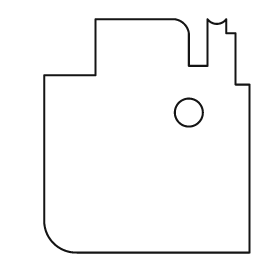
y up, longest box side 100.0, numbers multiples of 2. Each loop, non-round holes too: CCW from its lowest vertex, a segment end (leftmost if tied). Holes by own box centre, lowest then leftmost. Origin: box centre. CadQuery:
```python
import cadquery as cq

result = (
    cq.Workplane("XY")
    .moveTo(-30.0, -50.0)
    .lineTo(44.0, -50.0)
    .lineTo(44.0, 22.0)
    .lineTo(38.0, 22.0)
    .lineTo(38.0, 44.0)
    .lineTo(34.0, 44.0)
    .lineTo(34.0, 50.0)
    .threePointArc((30.0, 48.0), (26.0, 50.0))
    .lineTo(26.0, 30.0)
    .lineTo(18.0, 30.0)
    .lineTo(18.0, 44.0)
    .threePointArc((16.0, 48.0), (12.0, 50.0))
    .lineTo(-22.0, 50.0)
    .lineTo(-22.0, 26.0)
    .lineTo(-44.0, 26.0)
    .lineTo(-44.0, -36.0)
    .threePointArc((-40.0, -46.0), (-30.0, -50.0))
    .close()
    .moveTo(18.0, 10.0)
    .circle(6.0)
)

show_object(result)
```